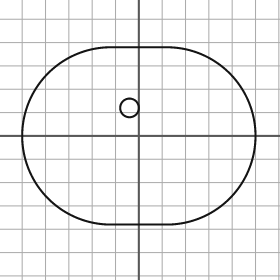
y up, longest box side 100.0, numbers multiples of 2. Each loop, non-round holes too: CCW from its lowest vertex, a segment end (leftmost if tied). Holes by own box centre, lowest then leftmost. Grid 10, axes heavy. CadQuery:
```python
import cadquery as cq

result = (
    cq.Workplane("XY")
    .moveTo(-12.0, -38.0)
    .lineTo(12.0, -38.0)
    .threePointArc((50.0, 0.0), (12.0, 38.0))
    .lineTo(-12.0, 38.0)
    .threePointArc((-50.0, 0.0), (-12.0, -38.0))
    .close()
    .moveTo(-4.0, 12.0)
    .circle(4.0)
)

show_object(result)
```